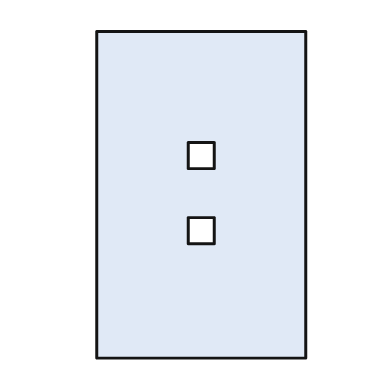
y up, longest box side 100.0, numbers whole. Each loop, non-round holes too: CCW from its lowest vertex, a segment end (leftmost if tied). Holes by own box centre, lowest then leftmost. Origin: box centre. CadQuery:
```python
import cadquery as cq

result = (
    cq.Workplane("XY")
    .moveTo(-32.0, -50.0)
    .lineTo(32.0, -50.0)
    .lineTo(32.0, 50.0)
    .lineTo(-32.0, 50.0)
    .close()
    .moveTo(-4.0, -15.0)
    .lineTo(4.0, -15.0)
    .lineTo(4.0, -7.0)
    .lineTo(-4.0, -7.0)
    .close()
    .moveTo(-4.0, 8.0)
    .lineTo(4.0, 8.0)
    .lineTo(4.0, 16.0)
    .lineTo(-4.0, 16.0)
    .close()
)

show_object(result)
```